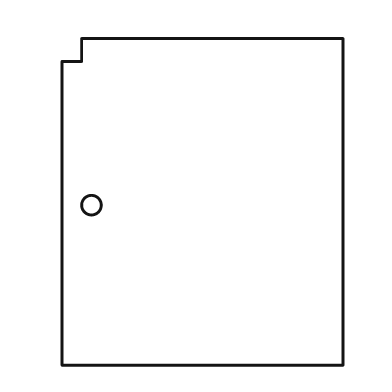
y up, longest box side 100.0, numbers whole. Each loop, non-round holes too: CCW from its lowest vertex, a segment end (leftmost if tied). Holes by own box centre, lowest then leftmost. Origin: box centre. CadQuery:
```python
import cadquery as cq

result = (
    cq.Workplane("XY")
    .moveTo(-43.0, -50.0)
    .lineTo(43.0, -50.0)
    .lineTo(43.0, 50.0)
    .lineTo(-37.0, 50.0)
    .lineTo(-37.0, 43.0)
    .lineTo(-43.0, 43.0)
    .close()
    .moveTo(-34.0, -1.0)
    .circle(3.0)
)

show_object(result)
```